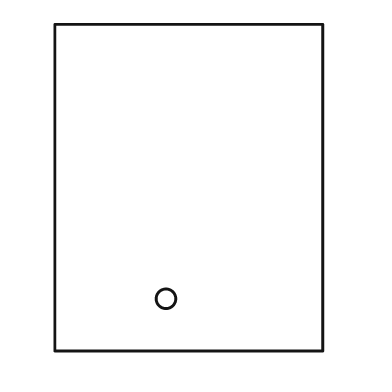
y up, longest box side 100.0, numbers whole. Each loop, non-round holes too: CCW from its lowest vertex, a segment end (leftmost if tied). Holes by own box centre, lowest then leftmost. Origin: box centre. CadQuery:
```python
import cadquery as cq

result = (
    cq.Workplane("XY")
    .moveTo(-41.0, -50.0)
    .lineTo(41.0, -50.0)
    .lineTo(41.0, 50.0)
    .lineTo(-41.0, 50.0)
    .close()
    .moveTo(-7.0, -34.0)
    .circle(3.0)
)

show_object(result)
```